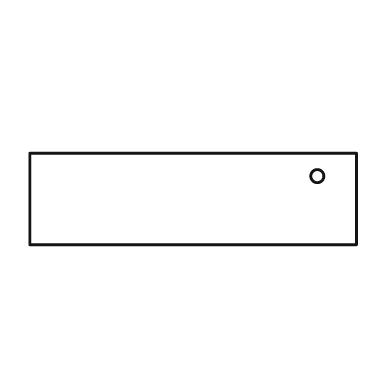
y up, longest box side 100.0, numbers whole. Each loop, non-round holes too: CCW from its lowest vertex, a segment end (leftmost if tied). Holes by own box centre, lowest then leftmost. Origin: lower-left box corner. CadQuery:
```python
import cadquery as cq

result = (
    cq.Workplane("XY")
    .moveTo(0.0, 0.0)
    .lineTo(100.0, 0.0)
    .lineTo(100.0, 28.0)
    .lineTo(0.0, 28.0)
    .close()
    .moveTo(88.0, 21.0)
    .circle(2.0)
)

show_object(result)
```